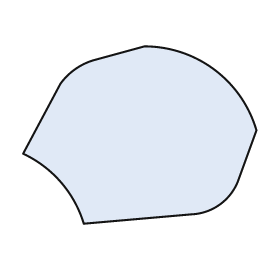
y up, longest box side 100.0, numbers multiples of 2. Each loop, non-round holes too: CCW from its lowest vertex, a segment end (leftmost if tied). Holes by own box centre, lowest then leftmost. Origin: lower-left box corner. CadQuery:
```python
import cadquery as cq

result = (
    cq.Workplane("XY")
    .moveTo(26.0, 0.0)
    .lineTo(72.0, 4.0)
    .threePointArc((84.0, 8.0), (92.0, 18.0))
    .lineTo(100.0, 40.0)
    .threePointArc((82.0, 66.0), (52.0, 76.0))
    .lineTo(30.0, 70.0)
    .threePointArc((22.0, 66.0), (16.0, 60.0))
    .lineTo(0.0, 30.0)
    .threePointArc((16.0, 18.0), (26.0, 0.0))
    .close()
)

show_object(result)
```